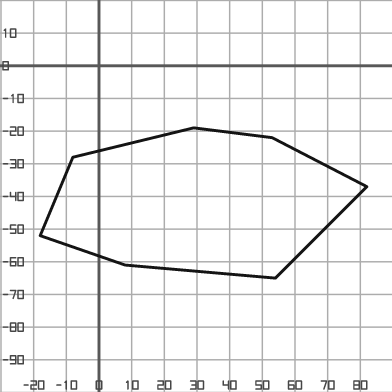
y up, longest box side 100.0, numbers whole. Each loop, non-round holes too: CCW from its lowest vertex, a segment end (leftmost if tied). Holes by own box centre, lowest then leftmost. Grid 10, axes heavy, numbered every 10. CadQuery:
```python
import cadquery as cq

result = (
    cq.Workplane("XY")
    .moveTo(54.0, -65.0)
    .lineTo(82.0, -37.0)
    .lineTo(53.0, -22.0)
    .lineTo(29.0, -19.0)
    .lineTo(-8.0, -28.0)
    .lineTo(-18.0, -52.0)
    .lineTo(8.0, -61.0)
    .close()
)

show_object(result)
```